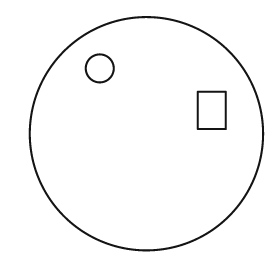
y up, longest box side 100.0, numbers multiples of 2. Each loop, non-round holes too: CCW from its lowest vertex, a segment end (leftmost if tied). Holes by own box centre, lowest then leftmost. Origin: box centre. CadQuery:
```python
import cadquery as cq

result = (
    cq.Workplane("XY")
    .moveTo(0.0, 0.0)
    .circle(50.0)
    .moveTo(22.0, 2.0)
    .lineTo(34.0, 2.0)
    .lineTo(34.0, 18.0)
    .lineTo(22.0, 18.0)
    .close()
    .moveTo(-20.0, 28.0)
    .circle(6.0)
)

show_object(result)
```